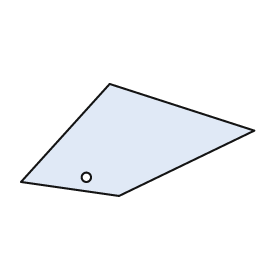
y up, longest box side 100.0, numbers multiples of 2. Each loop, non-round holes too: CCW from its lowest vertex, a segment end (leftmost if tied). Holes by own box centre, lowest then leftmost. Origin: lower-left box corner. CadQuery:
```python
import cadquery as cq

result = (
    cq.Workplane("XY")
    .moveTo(42.0, 0.0)
    .lineTo(100.0, 28.0)
    .lineTo(38.0, 48.0)
    .lineTo(0.0, 6.0)
    .close()
    .moveTo(28.0, 8.0)
    .circle(2.0)
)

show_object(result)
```